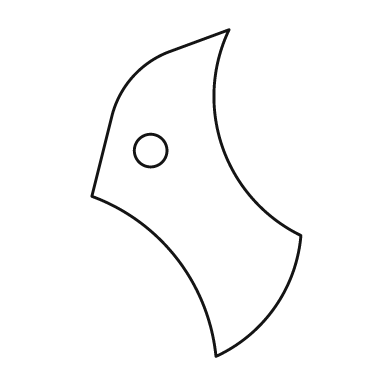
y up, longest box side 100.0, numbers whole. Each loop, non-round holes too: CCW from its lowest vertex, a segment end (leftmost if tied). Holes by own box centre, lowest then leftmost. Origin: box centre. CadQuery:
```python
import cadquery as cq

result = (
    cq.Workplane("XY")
    .moveTo(6.0, -50.0)
    .threePointArc((24.0, -35.0), (32.0, -13.0))
    .threePointArc((8.0, 14.0), (10.0, 50.0))
    .lineTo(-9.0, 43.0)
    .threePointArc((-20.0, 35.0), (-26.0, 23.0))
    .lineTo(-32.0, -1.0)
    .threePointArc((-6.0, -20.0), (6.0, -50.0))
    .close()
    .moveTo(-14.0, 13.0)
    .circle(5.0)
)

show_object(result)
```